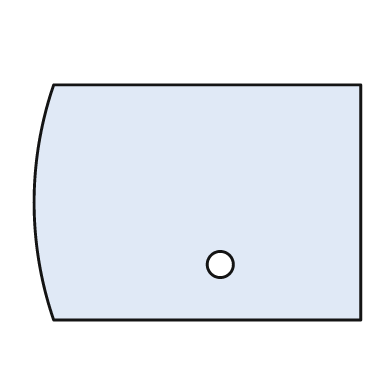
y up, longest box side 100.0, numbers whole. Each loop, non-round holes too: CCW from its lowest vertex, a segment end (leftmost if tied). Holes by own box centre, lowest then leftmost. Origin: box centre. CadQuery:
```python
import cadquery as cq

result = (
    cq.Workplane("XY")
    .moveTo(-44.0, -36.0)
    .lineTo(50.0, -36.0)
    .lineTo(50.0, 36.0)
    .lineTo(-44.0, 36.0)
    .threePointArc((-50.0, 0.0), (-44.0, -36.0))
    .close()
    .moveTo(7.0, -19.0)
    .circle(4.0)
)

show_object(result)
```